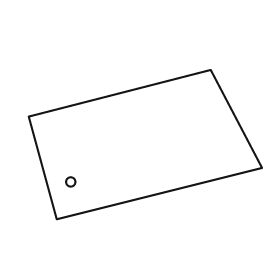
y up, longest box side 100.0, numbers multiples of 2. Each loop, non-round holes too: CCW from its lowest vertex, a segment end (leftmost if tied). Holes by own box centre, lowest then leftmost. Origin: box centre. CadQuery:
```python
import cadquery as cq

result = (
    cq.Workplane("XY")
    .moveTo(-38.0, -32.0)
    .lineTo(50.0, -10.0)
    .lineTo(28.0, 32.0)
    .lineTo(-50.0, 12.0)
    .close()
    .moveTo(-32.0, -16.0)
    .circle(2.0)
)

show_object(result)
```